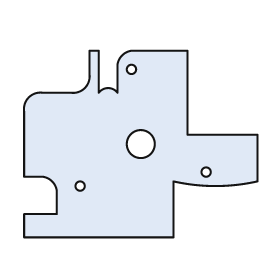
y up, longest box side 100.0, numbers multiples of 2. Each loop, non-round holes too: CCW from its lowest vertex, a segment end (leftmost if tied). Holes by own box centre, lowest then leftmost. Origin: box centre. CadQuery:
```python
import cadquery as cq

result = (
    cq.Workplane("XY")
    .moveTo(-50.0, -40.0)
    .lineTo(14.0, -40.0)
    .lineTo(14.0, -16.0)
    .threePointArc((32.0, -18.0), (50.0, -16.0))
    .lineTo(50.0, 4.0)
    .lineTo(20.0, 4.0)
    .lineTo(20.0, 40.0)
    .lineTo(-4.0, 40.0)
    .threePointArc((-8.0, 38.0), (-10.0, 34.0))
    .lineTo(-10.0, 22.0)
    .threePointArc((-14.0, 24.0), (-18.0, 22.0))
    .lineTo(-18.0, 40.0)
    .lineTo(-22.0, 40.0)
    .lineTo(-22.0, 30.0)
    .threePointArc((-24.0, 24.0), (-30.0, 22.0))
    .lineTo(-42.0, 22.0)
    .threePointArc((-48.0, 20.0), (-50.0, 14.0))
    .lineTo(-50.0, -14.0)
    .lineTo(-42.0, -14.0)
    .threePointArc((-38.0, -16.0), (-36.0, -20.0))
    .lineTo(-36.0, -30.0)
    .lineTo(-50.0, -30.0)
    .close()
    .moveTo(-26.0, -18.0)
    .circle(2.0)
    .moveTo(28.0, -12.0)
    .circle(2.0)
    .moveTo(0.0, 0.0)
    .circle(6.0)
    .moveTo(-4.0, 32.0)
    .circle(2.0)
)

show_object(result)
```